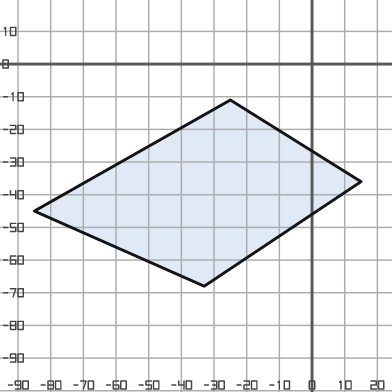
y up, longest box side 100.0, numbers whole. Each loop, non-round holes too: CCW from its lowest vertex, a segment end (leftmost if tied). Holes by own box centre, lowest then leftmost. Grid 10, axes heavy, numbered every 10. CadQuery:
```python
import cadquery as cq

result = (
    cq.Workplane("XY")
    .moveTo(-33.0, -68.0)
    .lineTo(15.0, -36.0)
    .lineTo(-25.0, -11.0)
    .lineTo(-85.0, -45.0)
    .close()
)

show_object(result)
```